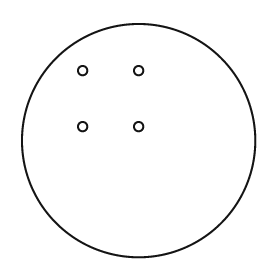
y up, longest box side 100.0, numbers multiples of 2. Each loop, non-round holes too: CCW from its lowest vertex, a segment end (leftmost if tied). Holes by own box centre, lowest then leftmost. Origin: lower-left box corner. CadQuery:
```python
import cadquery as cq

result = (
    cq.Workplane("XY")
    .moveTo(50.0, 50.0)
    .circle(50.0)
    .moveTo(26.0, 56.0)
    .circle(2.0)
    .moveTo(50.0, 56.0)
    .circle(2.0)
    .moveTo(26.0, 80.0)
    .circle(2.0)
    .moveTo(50.0, 80.0)
    .circle(2.0)
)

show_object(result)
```